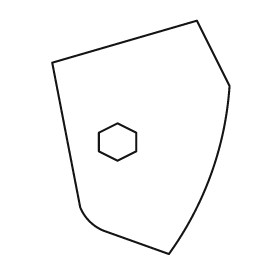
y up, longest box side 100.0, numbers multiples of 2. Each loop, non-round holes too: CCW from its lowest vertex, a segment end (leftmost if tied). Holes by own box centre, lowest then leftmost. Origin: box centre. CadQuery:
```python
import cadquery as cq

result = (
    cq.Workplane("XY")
    .moveTo(12.0, -50.0)
    .threePointArc((30.0, -16.0), (38.0, 22.0))
    .lineTo(24.0, 50.0)
    .lineTo(-38.0, 32.0)
    .lineTo(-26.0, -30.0)
    .threePointArc((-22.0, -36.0), (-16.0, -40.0))
    .close()
    .moveTo(-10.0, -10.0)
    .lineTo(-2.0, -6.0)
    .lineTo(-2.0, 2.0)
    .lineTo(-10.0, 6.0)
    .lineTo(-18.0, 2.0)
    .lineTo(-18.0, -6.0)
    .close()
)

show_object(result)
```